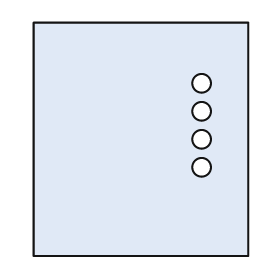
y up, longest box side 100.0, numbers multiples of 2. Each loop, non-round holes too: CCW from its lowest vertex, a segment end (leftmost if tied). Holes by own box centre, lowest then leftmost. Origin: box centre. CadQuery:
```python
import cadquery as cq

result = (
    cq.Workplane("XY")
    .moveTo(-46.0, -50.0)
    .lineTo(46.0, -50.0)
    .lineTo(46.0, 50.0)
    .lineTo(-46.0, 50.0)
    .close()
    .moveTo(26.0, -12.0)
    .circle(4.0)
    .moveTo(26.0, 0.0)
    .circle(4.0)
    .moveTo(26.0, 12.0)
    .circle(4.0)
    .moveTo(26.0, 24.0)
    .circle(4.0)
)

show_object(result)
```